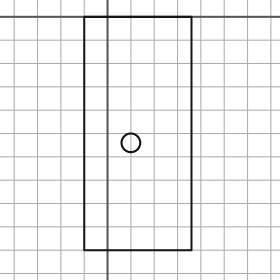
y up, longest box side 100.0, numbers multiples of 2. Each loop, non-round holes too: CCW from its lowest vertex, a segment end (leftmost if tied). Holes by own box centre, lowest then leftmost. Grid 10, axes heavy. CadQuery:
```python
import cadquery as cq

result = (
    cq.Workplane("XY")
    .moveTo(-10.0, -100.0)
    .lineTo(36.0, -100.0)
    .lineTo(36.0, 0.0)
    .lineTo(-10.0, 0.0)
    .close()
    .moveTo(10.0, -54.0)
    .circle(4.0)
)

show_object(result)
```